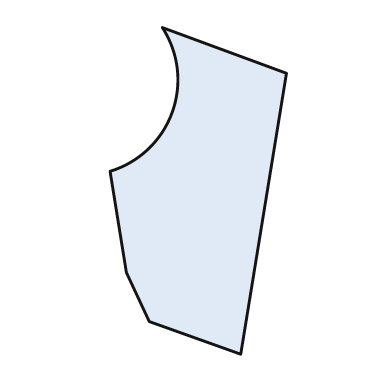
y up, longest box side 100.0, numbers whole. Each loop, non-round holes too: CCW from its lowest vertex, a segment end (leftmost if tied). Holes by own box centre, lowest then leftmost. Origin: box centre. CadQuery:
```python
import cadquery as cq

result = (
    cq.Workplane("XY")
    .moveTo(13.0, -50.0)
    .lineTo(27.0, 36.0)
    .lineTo(-11.0, 50.0)
    .threePointArc((-8.0, 24.0), (-27.0, 6.0))
    .lineTo(-22.0, -25.0)
    .lineTo(-15.0, -40.0)
    .close()
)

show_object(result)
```